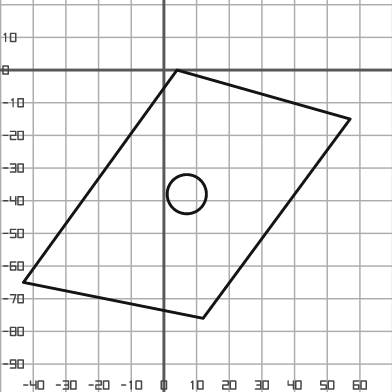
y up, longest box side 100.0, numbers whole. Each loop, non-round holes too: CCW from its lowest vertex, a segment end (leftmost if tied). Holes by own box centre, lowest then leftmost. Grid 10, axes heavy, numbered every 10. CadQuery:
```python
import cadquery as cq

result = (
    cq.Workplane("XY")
    .moveTo(12.0, -76.0)
    .lineTo(57.0, -15.0)
    .lineTo(4.0, 0.0)
    .lineTo(-43.0, -65.0)
    .close()
    .moveTo(7.0, -38.0)
    .circle(6.0)
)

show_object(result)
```